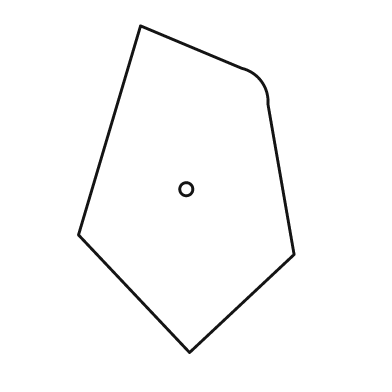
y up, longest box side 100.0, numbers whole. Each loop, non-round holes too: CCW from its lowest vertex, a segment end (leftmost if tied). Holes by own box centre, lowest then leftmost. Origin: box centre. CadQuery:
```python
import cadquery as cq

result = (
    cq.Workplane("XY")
    .moveTo(1.0, -50.0)
    .lineTo(33.0, -20.0)
    .lineTo(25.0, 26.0)
    .threePointArc((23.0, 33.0), (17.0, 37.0))
    .lineTo(-14.0, 50.0)
    .lineTo(-33.0, -14.0)
    .close()
    .moveTo(0.0, 0.0)
    .circle(2.0)
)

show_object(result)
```